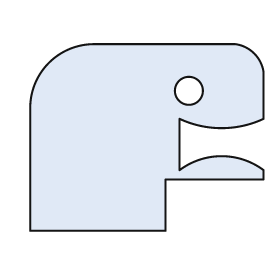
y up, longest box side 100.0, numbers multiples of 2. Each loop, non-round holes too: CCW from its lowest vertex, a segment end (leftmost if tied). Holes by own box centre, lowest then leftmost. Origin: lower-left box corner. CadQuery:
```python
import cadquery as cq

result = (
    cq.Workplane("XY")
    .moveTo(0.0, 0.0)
    .lineTo(58.0, 0.0)
    .lineTo(58.0, 22.0)
    .lineTo(100.0, 22.0)
    .lineTo(100.0, 26.0)
    .threePointArc((82.0, 32.0), (64.0, 26.0))
    .lineTo(64.0, 48.0)
    .threePointArc((82.0, 44.0), (100.0, 48.0))
    .lineTo(100.0, 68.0)
    .threePointArc((96.0, 76.0), (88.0, 80.0))
    .lineTo(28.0, 80.0)
    .threePointArc((8.0, 72.0), (0.0, 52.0))
    .close()
    .moveTo(68.0, 60.0)
    .circle(6.0)
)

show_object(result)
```